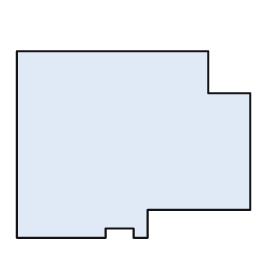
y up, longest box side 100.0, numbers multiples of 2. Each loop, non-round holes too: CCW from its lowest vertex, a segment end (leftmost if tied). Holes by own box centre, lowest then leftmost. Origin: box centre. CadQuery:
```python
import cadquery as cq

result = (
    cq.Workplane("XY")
    .moveTo(-50.0, -40.0)
    .lineTo(-12.0, -40.0)
    .lineTo(-12.0, -36.0)
    .lineTo(0.0, -36.0)
    .lineTo(0.0, -40.0)
    .lineTo(6.0, -40.0)
    .lineTo(6.0, -28.0)
    .lineTo(50.0, -28.0)
    .lineTo(50.0, 22.0)
    .lineTo(32.0, 22.0)
    .lineTo(32.0, 40.0)
    .lineTo(-50.0, 40.0)
    .close()
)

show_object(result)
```